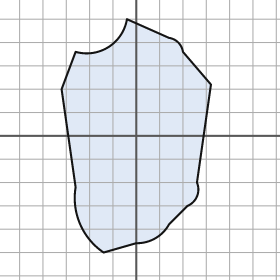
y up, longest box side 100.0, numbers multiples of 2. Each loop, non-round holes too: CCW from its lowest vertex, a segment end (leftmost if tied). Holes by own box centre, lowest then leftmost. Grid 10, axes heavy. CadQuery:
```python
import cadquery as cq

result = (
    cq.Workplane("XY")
    .moveTo(-14.0, -50.0)
    .lineTo(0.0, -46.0)
    .threePointArc((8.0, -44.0), (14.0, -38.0))
    .lineTo(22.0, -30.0)
    .threePointArc((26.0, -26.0), (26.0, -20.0))
    .lineTo(32.0, 22.0)
    .lineTo(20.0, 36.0)
    .threePointArc((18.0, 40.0), (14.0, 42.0))
    .lineTo(-4.0, 50.0)
    .threePointArc((-12.0, 38.0), (-26.0, 36.0))
    .lineTo(-32.0, 20.0)
    .lineTo(-26.0, -22.0)
    .threePointArc((-24.0, -38.0), (-14.0, -50.0))
    .close()
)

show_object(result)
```